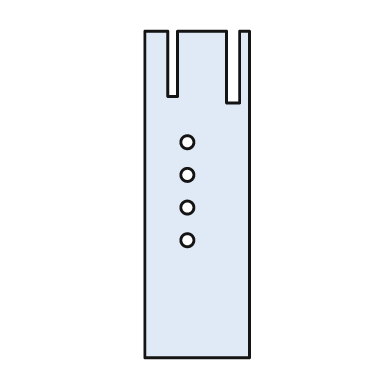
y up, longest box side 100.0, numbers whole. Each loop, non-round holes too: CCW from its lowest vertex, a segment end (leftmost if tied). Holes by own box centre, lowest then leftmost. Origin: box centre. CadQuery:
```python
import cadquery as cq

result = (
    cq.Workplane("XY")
    .moveTo(-16.0, -50.0)
    .lineTo(16.0, -50.0)
    .lineTo(16.0, 50.0)
    .lineTo(13.0, 50.0)
    .lineTo(13.0, 28.0)
    .lineTo(9.0, 28.0)
    .lineTo(9.0, 50.0)
    .lineTo(-6.0, 50.0)
    .lineTo(-6.0, 30.0)
    .lineTo(-9.0, 30.0)
    .lineTo(-9.0, 50.0)
    .lineTo(-16.0, 50.0)
    .close()
    .moveTo(-3.0, -14.0)
    .circle(2.0)
    .moveTo(-3.0, -4.0)
    .circle(2.0)
    .moveTo(-3.0, 6.0)
    .circle(2.0)
    .moveTo(-3.0, 16.0)
    .circle(2.0)
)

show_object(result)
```